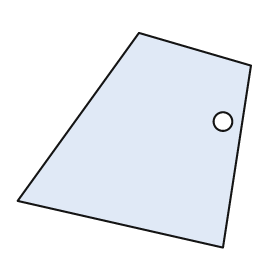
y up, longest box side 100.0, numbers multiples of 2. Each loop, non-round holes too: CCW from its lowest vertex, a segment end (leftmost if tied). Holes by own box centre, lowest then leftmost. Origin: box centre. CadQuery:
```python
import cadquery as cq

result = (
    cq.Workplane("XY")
    .moveTo(38.0, -46.0)
    .lineTo(50.0, 32.0)
    .lineTo(2.0, 46.0)
    .lineTo(-50.0, -26.0)
    .close()
    .moveTo(38.0, 8.0)
    .circle(4.0)
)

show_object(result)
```